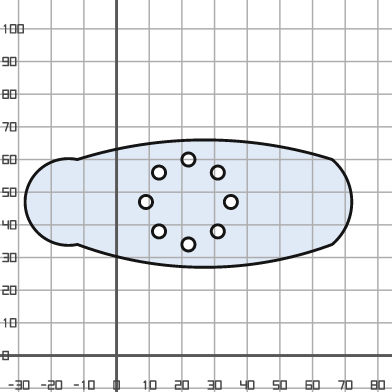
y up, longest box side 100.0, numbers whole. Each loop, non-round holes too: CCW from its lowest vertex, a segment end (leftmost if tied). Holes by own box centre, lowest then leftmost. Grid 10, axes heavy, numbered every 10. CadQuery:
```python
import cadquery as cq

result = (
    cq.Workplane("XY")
    .moveTo(-12.0, 34.0)
    .threePointArc((27.0, 27.0), (66.0, 34.0))
    .threePointArc((72.0, 47.0), (66.0, 60.0))
    .threePointArc((27.0, 66.0), (-12.0, 60.0))
    .threePointArc((-28.0, 47.0), (-12.0, 34.0))
    .close()
    .moveTo(22.0, 34.0)
    .circle(2.0)
    .moveTo(13.0, 38.0)
    .circle(2.0)
    .moveTo(31.0, 38.0)
    .circle(2.0)
    .moveTo(9.0, 47.0)
    .circle(2.0)
    .moveTo(35.0, 47.0)
    .circle(2.0)
    .moveTo(13.0, 56.0)
    .circle(2.0)
    .moveTo(31.0, 56.0)
    .circle(2.0)
    .moveTo(22.0, 60.0)
    .circle(2.0)
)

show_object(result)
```